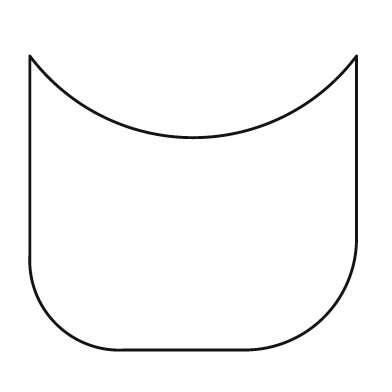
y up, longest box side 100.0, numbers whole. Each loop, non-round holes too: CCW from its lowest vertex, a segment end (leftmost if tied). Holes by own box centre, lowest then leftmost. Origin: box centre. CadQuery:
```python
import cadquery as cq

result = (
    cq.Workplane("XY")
    .moveTo(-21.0, -45.0)
    .lineTo(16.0, -45.0)
    .threePointArc((40.0, -35.0), (50.0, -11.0))
    .lineTo(50.0, 45.0)
    .threePointArc((0.0, 20.0), (-50.0, 45.0))
    .lineTo(-50.0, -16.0)
    .threePointArc((-42.0, -37.0), (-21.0, -45.0))
    .close()
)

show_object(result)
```